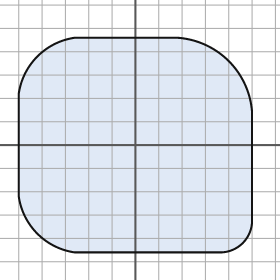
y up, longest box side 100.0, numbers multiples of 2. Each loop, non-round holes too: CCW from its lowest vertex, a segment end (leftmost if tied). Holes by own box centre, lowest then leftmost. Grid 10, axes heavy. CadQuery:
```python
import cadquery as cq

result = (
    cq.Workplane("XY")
    .moveTo(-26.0, -46.0)
    .lineTo(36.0, -46.0)
    .threePointArc((46.0, -42.0), (50.0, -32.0))
    .lineTo(50.0, 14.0)
    .threePointArc((40.0, 36.0), (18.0, 46.0))
    .lineTo(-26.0, 46.0)
    .threePointArc((-42.0, 38.0), (-50.0, 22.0))
    .lineTo(-50.0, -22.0)
    .threePointArc((-42.0, -38.0), (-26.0, -46.0))
    .close()
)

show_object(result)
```